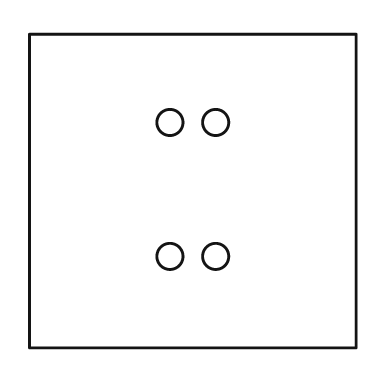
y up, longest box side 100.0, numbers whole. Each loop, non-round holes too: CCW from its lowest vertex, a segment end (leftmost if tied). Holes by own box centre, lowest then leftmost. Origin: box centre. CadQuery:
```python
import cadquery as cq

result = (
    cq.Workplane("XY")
    .moveTo(-50.0, -48.0)
    .lineTo(50.0, -48.0)
    .lineTo(50.0, 48.0)
    .lineTo(-50.0, 48.0)
    .close()
    .moveTo(-7.0, -20.0)
    .circle(4.0)
    .moveTo(7.0, -20.0)
    .circle(4.0)
    .moveTo(-7.0, 21.0)
    .circle(4.0)
    .moveTo(7.0, 21.0)
    .circle(4.0)
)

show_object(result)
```